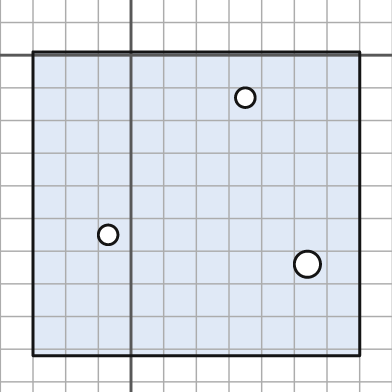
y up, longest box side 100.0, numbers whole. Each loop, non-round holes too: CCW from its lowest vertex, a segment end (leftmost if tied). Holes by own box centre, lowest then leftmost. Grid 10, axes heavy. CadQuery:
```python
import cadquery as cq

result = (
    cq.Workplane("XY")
    .moveTo(-30.0, -92.0)
    .lineTo(70.0, -92.0)
    .lineTo(70.0, 1.0)
    .lineTo(-30.0, 1.0)
    .close()
    .moveTo(54.0, -64.0)
    .circle(4.0)
    .moveTo(-7.0, -55.0)
    .circle(3.0)
    .moveTo(35.0, -13.0)
    .circle(3.0)
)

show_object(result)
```